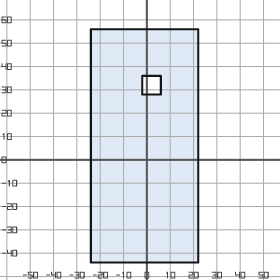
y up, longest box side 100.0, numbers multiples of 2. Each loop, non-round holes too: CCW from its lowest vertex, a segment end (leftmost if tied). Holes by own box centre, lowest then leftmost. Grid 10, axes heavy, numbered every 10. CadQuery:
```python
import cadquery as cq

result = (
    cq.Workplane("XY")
    .moveTo(-24.0, -44.0)
    .lineTo(22.0, -44.0)
    .lineTo(22.0, 56.0)
    .lineTo(-24.0, 56.0)
    .close()
    .moveTo(-2.0, 28.0)
    .lineTo(6.0, 28.0)
    .lineTo(6.0, 36.0)
    .lineTo(-2.0, 36.0)
    .close()
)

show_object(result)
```